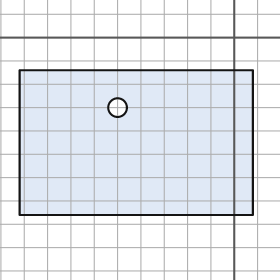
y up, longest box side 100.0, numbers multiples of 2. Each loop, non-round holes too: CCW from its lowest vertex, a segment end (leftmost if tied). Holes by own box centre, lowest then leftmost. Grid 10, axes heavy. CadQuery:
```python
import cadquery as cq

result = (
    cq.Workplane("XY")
    .moveTo(-92.0, -76.0)
    .lineTo(8.0, -76.0)
    .lineTo(8.0, -14.0)
    .lineTo(-92.0, -14.0)
    .close()
    .moveTo(-50.0, -30.0)
    .circle(4.0)
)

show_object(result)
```